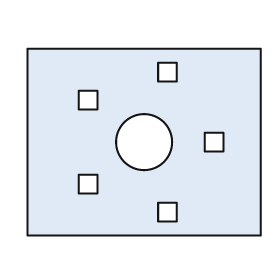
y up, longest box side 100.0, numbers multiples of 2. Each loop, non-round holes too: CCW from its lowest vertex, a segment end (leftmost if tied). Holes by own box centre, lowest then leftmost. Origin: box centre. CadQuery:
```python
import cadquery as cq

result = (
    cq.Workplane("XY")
    .moveTo(-50.0, -40.0)
    .lineTo(50.0, -40.0)
    .lineTo(50.0, 40.0)
    .lineTo(-50.0, 40.0)
    .close()
    .moveTo(6.0, -34.0)
    .lineTo(14.0, -34.0)
    .lineTo(14.0, -26.0)
    .lineTo(6.0, -26.0)
    .close()
    .moveTo(-28.0, -22.0)
    .lineTo(-20.0, -22.0)
    .lineTo(-20.0, -14.0)
    .lineTo(-28.0, -14.0)
    .close()
    .moveTo(0.0, 0.0)
    .circle(12.0)
    .moveTo(26.0, -4.0)
    .lineTo(34.0, -4.0)
    .lineTo(34.0, 4.0)
    .lineTo(26.0, 4.0)
    .close()
    .moveTo(-28.0, 14.0)
    .lineTo(-20.0, 14.0)
    .lineTo(-20.0, 22.0)
    .lineTo(-28.0, 22.0)
    .close()
    .moveTo(6.0, 26.0)
    .lineTo(14.0, 26.0)
    .lineTo(14.0, 34.0)
    .lineTo(6.0, 34.0)
    .close()
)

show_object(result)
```